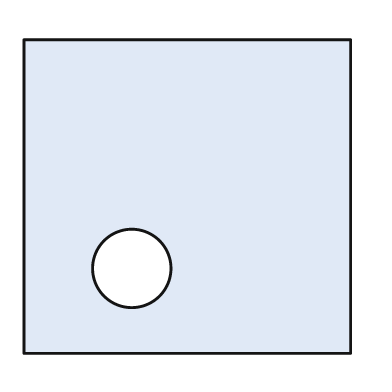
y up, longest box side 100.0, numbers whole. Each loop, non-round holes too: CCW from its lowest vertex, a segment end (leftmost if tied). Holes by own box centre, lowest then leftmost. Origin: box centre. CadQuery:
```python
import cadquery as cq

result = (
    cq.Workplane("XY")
    .moveTo(-50.0, -48.0)
    .lineTo(50.0, -48.0)
    .lineTo(50.0, 48.0)
    .lineTo(-50.0, 48.0)
    .close()
    .moveTo(-17.0, -22.0)
    .circle(12.0)
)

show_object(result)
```